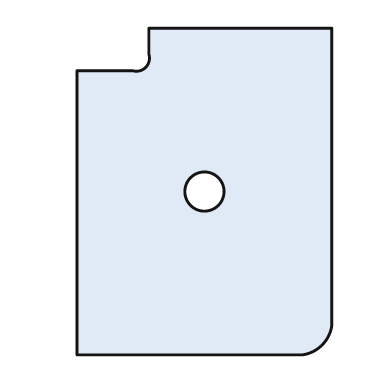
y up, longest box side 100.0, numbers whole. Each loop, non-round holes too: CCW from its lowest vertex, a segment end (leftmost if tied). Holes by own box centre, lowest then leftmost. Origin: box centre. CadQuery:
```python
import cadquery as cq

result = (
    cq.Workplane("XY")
    .moveTo(-39.0, -50.0)
    .lineTo(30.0, -50.0)
    .threePointArc((36.0, -47.0), (39.0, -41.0))
    .lineTo(39.0, 50.0)
    .lineTo(-17.0, 50.0)
    .lineTo(-17.0, 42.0)
    .threePointArc((-18.0, 38.0), (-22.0, 37.0))
    .lineTo(-39.0, 37.0)
    .close()
    .moveTo(0.0, 0.0)
    .circle(6.0)
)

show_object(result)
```